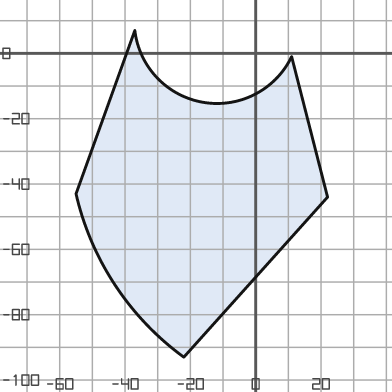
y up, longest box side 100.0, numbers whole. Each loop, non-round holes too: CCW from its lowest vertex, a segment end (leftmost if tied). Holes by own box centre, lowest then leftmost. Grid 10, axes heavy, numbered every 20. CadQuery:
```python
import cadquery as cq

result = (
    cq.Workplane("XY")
    .moveTo(-22.0, -93.0)
    .lineTo(22.0, -44.0)
    .lineTo(11.0, -1.0)
    .threePointArc((-16.0, -15.0), (-37.0, 7.0))
    .lineTo(-55.0, -43.0)
    .threePointArc((-43.0, -71.0), (-22.0, -93.0))
    .close()
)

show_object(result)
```